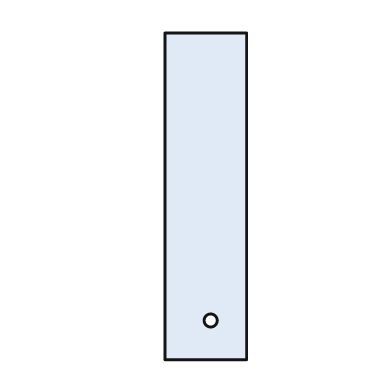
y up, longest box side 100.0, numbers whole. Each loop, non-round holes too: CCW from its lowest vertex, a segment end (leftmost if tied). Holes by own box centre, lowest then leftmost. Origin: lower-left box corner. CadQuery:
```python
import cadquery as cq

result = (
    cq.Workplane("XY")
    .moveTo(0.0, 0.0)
    .lineTo(25.0, 0.0)
    .lineTo(25.0, 100.0)
    .lineTo(0.0, 100.0)
    .close()
    .moveTo(14.0, 12.0)
    .circle(2.0)
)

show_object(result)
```